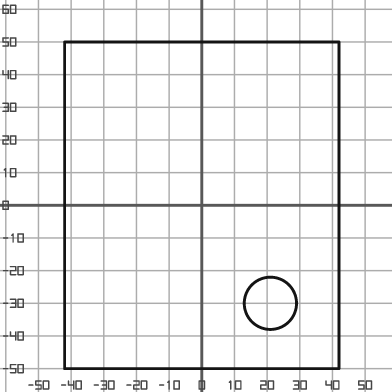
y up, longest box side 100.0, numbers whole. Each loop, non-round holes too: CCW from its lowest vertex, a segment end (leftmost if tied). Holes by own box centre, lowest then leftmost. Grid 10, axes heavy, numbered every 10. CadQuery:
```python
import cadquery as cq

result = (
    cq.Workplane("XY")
    .moveTo(-42.0, -50.0)
    .lineTo(42.0, -50.0)
    .lineTo(42.0, 50.0)
    .lineTo(-42.0, 50.0)
    .close()
    .moveTo(21.0, -30.0)
    .circle(8.0)
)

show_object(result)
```